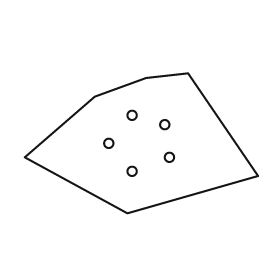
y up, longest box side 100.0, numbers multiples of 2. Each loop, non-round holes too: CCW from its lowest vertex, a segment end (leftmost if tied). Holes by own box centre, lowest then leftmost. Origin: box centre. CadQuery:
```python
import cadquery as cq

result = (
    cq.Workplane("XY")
    .moveTo(-6.0, -30.0)
    .lineTo(50.0, -14.0)
    .lineTo(20.0, 30.0)
    .lineTo(2.0, 28.0)
    .lineTo(-20.0, 20.0)
    .lineTo(-50.0, -6.0)
    .close()
    .moveTo(-4.0, -12.0)
    .circle(2.0)
    .moveTo(12.0, -6.0)
    .circle(2.0)
    .moveTo(-14.0, 0.0)
    .circle(2.0)
    .moveTo(10.0, 8.0)
    .circle(2.0)
    .moveTo(-4.0, 12.0)
    .circle(2.0)
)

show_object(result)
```